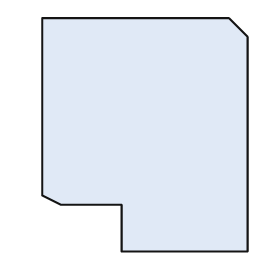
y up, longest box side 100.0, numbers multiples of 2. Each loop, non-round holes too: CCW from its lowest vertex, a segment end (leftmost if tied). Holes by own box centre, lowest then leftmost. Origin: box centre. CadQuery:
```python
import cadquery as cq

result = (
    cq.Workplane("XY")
    .moveTo(-10.0, -50.0)
    .lineTo(44.0, -50.0)
    .lineTo(44.0, 42.0)
    .lineTo(36.0, 50.0)
    .lineTo(-44.0, 50.0)
    .lineTo(-44.0, -26.0)
    .lineTo(-36.0, -30.0)
    .lineTo(-10.0, -30.0)
    .close()
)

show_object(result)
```